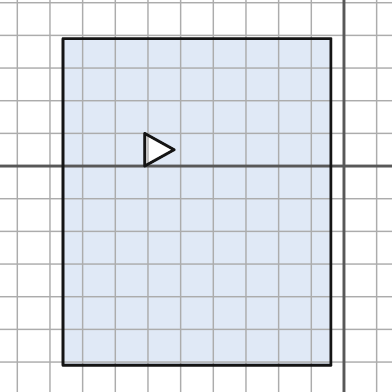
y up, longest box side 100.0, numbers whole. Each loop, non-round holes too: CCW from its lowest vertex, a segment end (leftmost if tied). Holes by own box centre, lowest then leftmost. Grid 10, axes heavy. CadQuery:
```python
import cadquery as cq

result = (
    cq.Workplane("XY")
    .moveTo(-86.0, -61.0)
    .lineTo(-4.0, -61.0)
    .lineTo(-4.0, 39.0)
    .lineTo(-86.0, 39.0)
    .close()
    .moveTo(-61.0, 0.0)
    .lineTo(-52.0, 5.0)
    .lineTo(-61.0, 10.0)
    .close()
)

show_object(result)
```